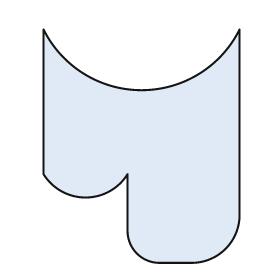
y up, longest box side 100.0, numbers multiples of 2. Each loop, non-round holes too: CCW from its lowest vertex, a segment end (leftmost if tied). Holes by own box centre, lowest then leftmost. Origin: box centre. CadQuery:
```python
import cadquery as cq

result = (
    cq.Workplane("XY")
    .moveTo(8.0, -50.0)
    .lineTo(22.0, -50.0)
    .threePointArc((36.0, -44.0), (42.0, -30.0))
    .lineTo(42.0, 50.0)
    .threePointArc((0.0, 24.0), (-42.0, 50.0))
    .lineTo(-42.0, -12.0)
    .threePointArc((-24.0, -22.0), (-6.0, -12.0))
    .lineTo(-6.0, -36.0)
    .threePointArc((-2.0, -46.0), (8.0, -50.0))
    .close()
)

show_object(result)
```